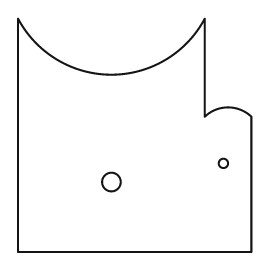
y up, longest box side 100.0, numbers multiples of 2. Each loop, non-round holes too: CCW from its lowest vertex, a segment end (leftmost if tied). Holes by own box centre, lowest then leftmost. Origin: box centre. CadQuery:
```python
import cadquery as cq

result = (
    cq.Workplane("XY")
    .moveTo(-50.0, -50.0)
    .lineTo(50.0, -50.0)
    .lineTo(50.0, 8.0)
    .threePointArc((40.0, 12.0), (30.0, 8.0))
    .lineTo(30.0, 50.0)
    .threePointArc((-10.0, 26.0), (-50.0, 50.0))
    .close()
    .moveTo(-10.0, -20.0)
    .circle(4.0)
    .moveTo(38.0, -12.0)
    .circle(2.0)
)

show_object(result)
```